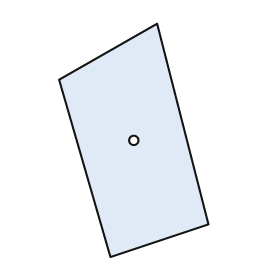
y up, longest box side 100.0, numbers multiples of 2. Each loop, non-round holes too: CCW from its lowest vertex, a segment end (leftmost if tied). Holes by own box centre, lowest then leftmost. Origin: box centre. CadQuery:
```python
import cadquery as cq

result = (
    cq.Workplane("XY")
    .moveTo(-10.0, -50.0)
    .lineTo(32.0, -36.0)
    .lineTo(10.0, 50.0)
    .lineTo(-32.0, 26.0)
    .close()
    .moveTo(0.0, 0.0)
    .circle(2.0)
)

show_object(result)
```